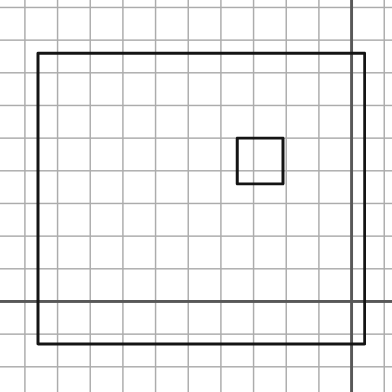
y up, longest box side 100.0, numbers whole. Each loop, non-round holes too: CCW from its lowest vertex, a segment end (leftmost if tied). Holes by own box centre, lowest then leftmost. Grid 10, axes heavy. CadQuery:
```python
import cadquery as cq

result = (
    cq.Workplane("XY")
    .moveTo(-96.0, -13.0)
    .lineTo(4.0, -13.0)
    .lineTo(4.0, 76.0)
    .lineTo(-96.0, 76.0)
    .close()
    .moveTo(-35.0, 36.0)
    .lineTo(-21.0, 36.0)
    .lineTo(-21.0, 50.0)
    .lineTo(-35.0, 50.0)
    .close()
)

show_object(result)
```